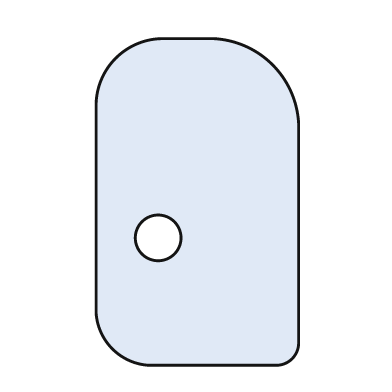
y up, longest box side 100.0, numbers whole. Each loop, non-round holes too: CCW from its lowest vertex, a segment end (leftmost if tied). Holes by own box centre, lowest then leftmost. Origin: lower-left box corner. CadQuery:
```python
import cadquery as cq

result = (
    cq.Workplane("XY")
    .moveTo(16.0, 0.0)
    .lineTo(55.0, 0.0)
    .threePointArc((60.0, 2.0), (62.0, 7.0))
    .lineTo(62.0, 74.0)
    .threePointArc((54.0, 92.0), (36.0, 100.0))
    .lineTo(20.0, 100.0)
    .threePointArc((6.0, 94.0), (0.0, 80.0))
    .lineTo(0.0, 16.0)
    .threePointArc((5.0, 5.0), (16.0, 0.0))
    .close()
    .moveTo(19.0, 39.0)
    .circle(7.0)
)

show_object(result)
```